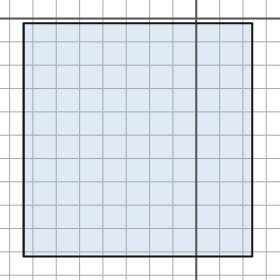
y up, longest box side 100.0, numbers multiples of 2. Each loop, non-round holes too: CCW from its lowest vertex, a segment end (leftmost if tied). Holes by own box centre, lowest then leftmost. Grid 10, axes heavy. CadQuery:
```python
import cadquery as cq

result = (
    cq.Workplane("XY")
    .moveTo(-74.0, -102.0)
    .lineTo(24.0, -102.0)
    .lineTo(24.0, -2.0)
    .lineTo(-74.0, -2.0)
    .close()
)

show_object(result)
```